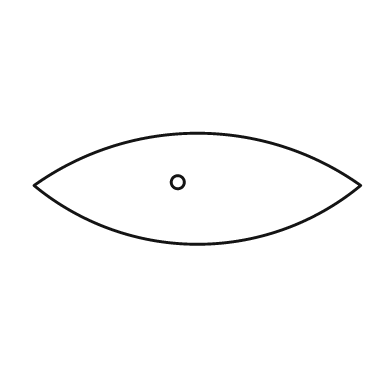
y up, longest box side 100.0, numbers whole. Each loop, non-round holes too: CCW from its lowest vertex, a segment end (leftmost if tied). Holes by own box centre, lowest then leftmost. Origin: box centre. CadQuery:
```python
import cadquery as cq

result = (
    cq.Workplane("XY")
    .moveTo(-50.0, 1.0)
    .threePointArc((0.0, -17.0), (50.0, 1.0))
    .threePointArc((0.0, 17.0), (-50.0, 1.0))
    .close()
    .moveTo(-6.0, 2.0)
    .circle(2.0)
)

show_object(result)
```